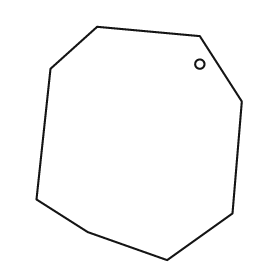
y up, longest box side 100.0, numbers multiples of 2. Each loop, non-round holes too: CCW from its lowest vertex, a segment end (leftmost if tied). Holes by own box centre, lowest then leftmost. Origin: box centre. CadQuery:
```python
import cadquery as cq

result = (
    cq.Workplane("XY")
    .moveTo(12.0, -50.0)
    .lineTo(40.0, -30.0)
    .lineTo(44.0, 18.0)
    .lineTo(26.0, 46.0)
    .lineTo(-18.0, 50.0)
    .lineTo(-38.0, 32.0)
    .lineTo(-44.0, -24.0)
    .lineTo(-22.0, -38.0)
    .close()
    .moveTo(26.0, 34.0)
    .circle(2.0)
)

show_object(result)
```